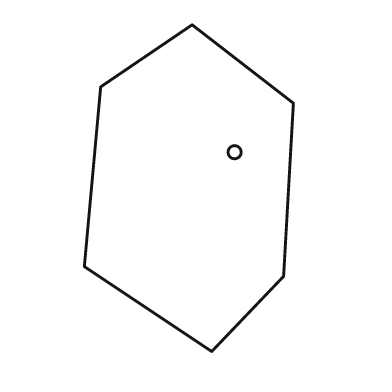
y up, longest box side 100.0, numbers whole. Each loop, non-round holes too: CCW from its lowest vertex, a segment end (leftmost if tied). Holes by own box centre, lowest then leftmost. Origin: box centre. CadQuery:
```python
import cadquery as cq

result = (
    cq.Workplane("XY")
    .moveTo(7.0, -50.0)
    .lineTo(29.0, -27.0)
    .lineTo(32.0, 26.0)
    .lineTo(1.0, 50.0)
    .lineTo(-27.0, 31.0)
    .lineTo(-32.0, -24.0)
    .close()
    .moveTo(14.0, 11.0)
    .circle(2.0)
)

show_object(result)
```